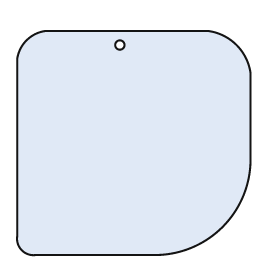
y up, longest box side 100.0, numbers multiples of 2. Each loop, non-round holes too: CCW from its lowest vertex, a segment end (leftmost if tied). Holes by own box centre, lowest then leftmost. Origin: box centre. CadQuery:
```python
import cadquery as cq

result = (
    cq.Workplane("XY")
    .moveTo(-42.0, -48.0)
    .lineTo(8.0, -48.0)
    .threePointArc((38.0, -36.0), (50.0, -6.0))
    .lineTo(50.0, 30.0)
    .threePointArc((44.0, 42.0), (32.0, 48.0))
    .lineTo(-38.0, 48.0)
    .threePointArc((-46.0, 44.0), (-50.0, 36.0))
    .lineTo(-50.0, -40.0)
    .threePointArc((-48.0, -46.0), (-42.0, -48.0))
    .close()
    .moveTo(-6.0, 42.0)
    .circle(2.0)
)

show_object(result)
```